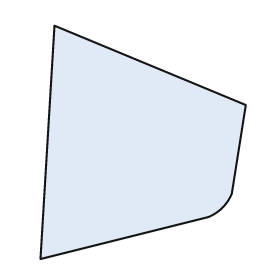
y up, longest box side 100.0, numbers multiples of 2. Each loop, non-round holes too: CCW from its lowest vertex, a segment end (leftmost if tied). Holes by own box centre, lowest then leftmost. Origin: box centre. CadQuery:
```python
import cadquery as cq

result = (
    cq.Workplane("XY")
    .moveTo(-44.0, -50.0)
    .lineTo(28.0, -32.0)
    .threePointArc((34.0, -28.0), (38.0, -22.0))
    .lineTo(44.0, 16.0)
    .lineTo(-38.0, 50.0)
    .close()
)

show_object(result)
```